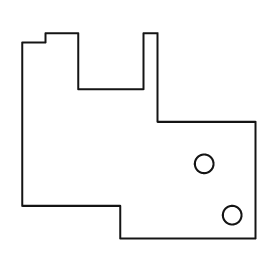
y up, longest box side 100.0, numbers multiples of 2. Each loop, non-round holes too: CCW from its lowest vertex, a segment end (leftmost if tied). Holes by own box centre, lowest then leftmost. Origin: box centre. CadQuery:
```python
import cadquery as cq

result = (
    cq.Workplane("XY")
    .moveTo(-8.0, -44.0)
    .lineTo(50.0, -44.0)
    .lineTo(50.0, 6.0)
    .lineTo(8.0, 6.0)
    .lineTo(8.0, 44.0)
    .lineTo(2.0, 44.0)
    .lineTo(2.0, 20.0)
    .lineTo(-26.0, 20.0)
    .lineTo(-26.0, 44.0)
    .lineTo(-40.0, 44.0)
    .lineTo(-40.0, 40.0)
    .lineTo(-50.0, 40.0)
    .lineTo(-50.0, -30.0)
    .lineTo(-8.0, -30.0)
    .close()
    .moveTo(40.0, -34.0)
    .circle(4.0)
    .moveTo(28.0, -12.0)
    .circle(4.0)
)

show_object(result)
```